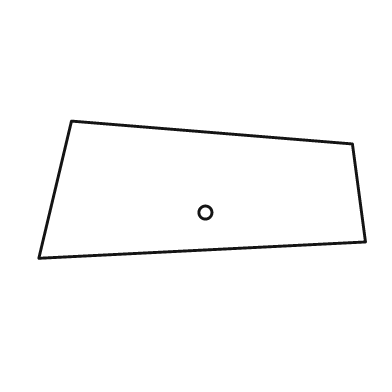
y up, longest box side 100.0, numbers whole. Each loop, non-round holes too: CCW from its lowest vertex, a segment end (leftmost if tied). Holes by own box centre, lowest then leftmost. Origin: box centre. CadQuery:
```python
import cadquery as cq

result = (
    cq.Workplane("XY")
    .moveTo(-50.0, -21.0)
    .lineTo(50.0, -16.0)
    .lineTo(46.0, 14.0)
    .lineTo(-40.0, 21.0)
    .close()
    .moveTo(1.0, -7.0)
    .circle(2.0)
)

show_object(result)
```